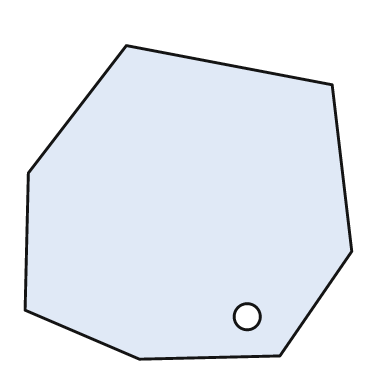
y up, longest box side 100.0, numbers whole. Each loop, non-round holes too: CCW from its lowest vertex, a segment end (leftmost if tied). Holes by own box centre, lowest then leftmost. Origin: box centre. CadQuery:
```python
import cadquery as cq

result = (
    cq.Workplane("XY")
    .moveTo(-15.0, -48.0)
    .lineTo(28.0, -47.0)
    .lineTo(50.0, -15.0)
    .lineTo(44.0, 36.0)
    .lineTo(-19.0, 48.0)
    .lineTo(-49.0, 9.0)
    .lineTo(-50.0, -33.0)
    .close()
    .moveTo(18.0, -35.0)
    .circle(4.0)
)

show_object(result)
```